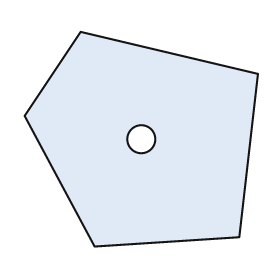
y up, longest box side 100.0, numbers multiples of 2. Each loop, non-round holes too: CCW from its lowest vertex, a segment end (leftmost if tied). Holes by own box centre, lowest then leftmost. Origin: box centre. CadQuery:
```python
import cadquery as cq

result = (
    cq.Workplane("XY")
    .moveTo(-20.0, -46.0)
    .lineTo(42.0, -42.0)
    .lineTo(50.0, 28.0)
    .lineTo(-26.0, 46.0)
    .lineTo(-50.0, 10.0)
    .close()
    .moveTo(0.0, 0.0)
    .circle(6.0)
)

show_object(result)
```